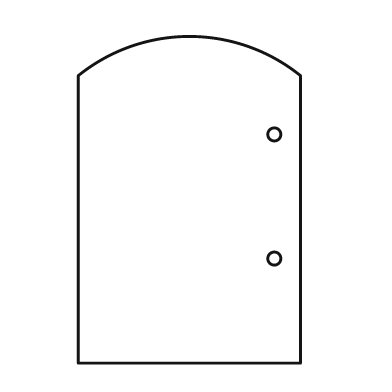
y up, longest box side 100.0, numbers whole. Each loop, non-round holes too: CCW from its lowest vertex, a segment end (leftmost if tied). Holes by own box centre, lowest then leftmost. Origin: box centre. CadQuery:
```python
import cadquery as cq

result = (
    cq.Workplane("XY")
    .moveTo(-34.0, -50.0)
    .lineTo(34.0, -50.0)
    .lineTo(34.0, 38.0)
    .threePointArc((0.0, 50.0), (-34.0, 38.0))
    .close()
    .moveTo(26.0, -18.0)
    .circle(2.0)
    .moveTo(26.0, 20.0)
    .circle(2.0)
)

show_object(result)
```